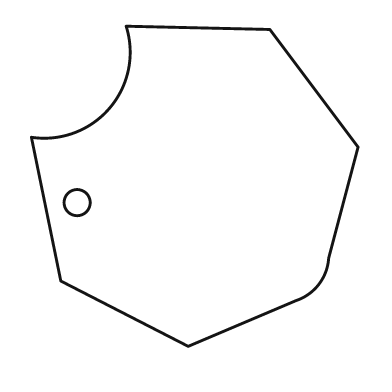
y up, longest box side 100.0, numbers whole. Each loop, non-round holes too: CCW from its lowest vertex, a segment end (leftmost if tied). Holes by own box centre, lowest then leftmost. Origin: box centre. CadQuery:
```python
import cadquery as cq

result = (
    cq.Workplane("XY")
    .moveTo(-2.0, -49.0)
    .lineTo(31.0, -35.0)
    .threePointArc((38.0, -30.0), (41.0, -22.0))
    .lineTo(50.0, 12.0)
    .lineTo(23.0, 48.0)
    .lineTo(-21.0, 49.0)
    .threePointArc((-26.0, 24.0), (-50.0, 15.0))
    .lineTo(-41.0, -29.0)
    .close()
    .moveTo(-36.0, -5.0)
    .circle(4.0)
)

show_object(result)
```